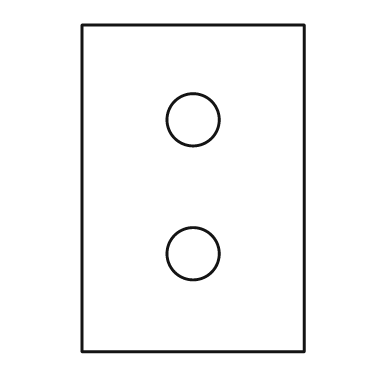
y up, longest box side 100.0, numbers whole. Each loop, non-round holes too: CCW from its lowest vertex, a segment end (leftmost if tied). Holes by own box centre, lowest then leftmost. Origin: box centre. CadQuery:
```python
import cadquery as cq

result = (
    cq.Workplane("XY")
    .moveTo(-34.0, -50.0)
    .lineTo(34.0, -50.0)
    .lineTo(34.0, 50.0)
    .lineTo(-34.0, 50.0)
    .close()
    .moveTo(0.0, -20.0)
    .circle(8.0)
    .moveTo(0.0, 21.0)
    .circle(8.0)
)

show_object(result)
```